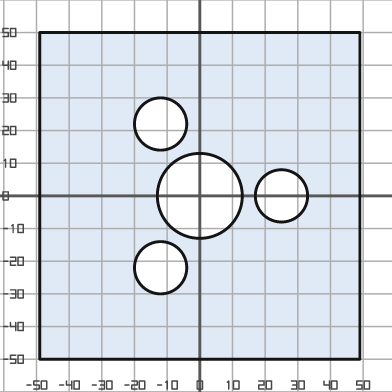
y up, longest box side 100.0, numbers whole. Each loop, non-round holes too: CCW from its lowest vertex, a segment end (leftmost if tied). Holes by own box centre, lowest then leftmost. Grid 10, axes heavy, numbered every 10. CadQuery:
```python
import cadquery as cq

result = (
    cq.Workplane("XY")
    .moveTo(-49.0, -50.0)
    .lineTo(49.0, -50.0)
    .lineTo(49.0, 50.0)
    .lineTo(-49.0, 50.0)
    .close()
    .moveTo(-12.0, -22.0)
    .circle(8.0)
    .moveTo(0.0, 0.0)
    .circle(13.0)
    .moveTo(25.0, 0.0)
    .circle(8.0)
    .moveTo(-12.0, 22.0)
    .circle(8.0)
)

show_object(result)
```